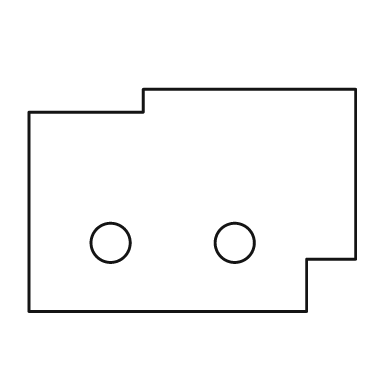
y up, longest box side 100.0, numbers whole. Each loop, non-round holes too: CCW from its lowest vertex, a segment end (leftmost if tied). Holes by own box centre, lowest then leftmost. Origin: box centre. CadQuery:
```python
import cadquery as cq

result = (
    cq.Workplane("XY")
    .moveTo(-50.0, -34.0)
    .lineTo(35.0, -34.0)
    .lineTo(35.0, -18.0)
    .lineTo(50.0, -18.0)
    .lineTo(50.0, 34.0)
    .lineTo(-15.0, 34.0)
    .lineTo(-15.0, 27.0)
    .lineTo(-50.0, 27.0)
    .close()
    .moveTo(-25.0, -13.0)
    .circle(6.0)
    .moveTo(13.0, -13.0)
    .circle(6.0)
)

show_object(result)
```